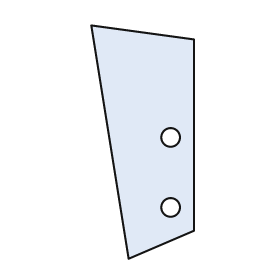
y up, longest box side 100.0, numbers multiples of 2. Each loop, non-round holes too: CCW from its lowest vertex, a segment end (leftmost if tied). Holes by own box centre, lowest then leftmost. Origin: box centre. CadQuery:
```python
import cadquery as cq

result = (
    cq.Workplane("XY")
    .moveTo(-6.0, -50.0)
    .lineTo(22.0, -38.0)
    .lineTo(22.0, 44.0)
    .lineTo(-22.0, 50.0)
    .close()
    .moveTo(12.0, -28.0)
    .circle(4.0)
    .moveTo(12.0, 2.0)
    .circle(4.0)
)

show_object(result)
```